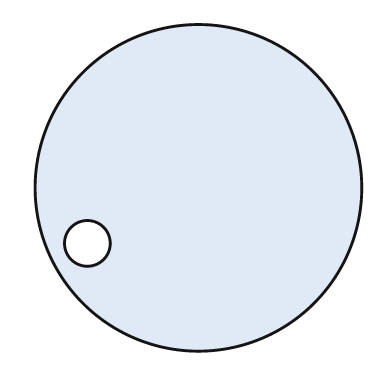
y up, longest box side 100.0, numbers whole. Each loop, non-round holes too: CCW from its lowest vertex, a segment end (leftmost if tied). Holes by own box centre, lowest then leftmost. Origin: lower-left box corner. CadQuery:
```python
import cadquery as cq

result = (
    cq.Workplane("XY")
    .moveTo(50.0, 50.0)
    .circle(50.0)
    .moveTo(16.0, 33.0)
    .circle(7.0)
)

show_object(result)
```